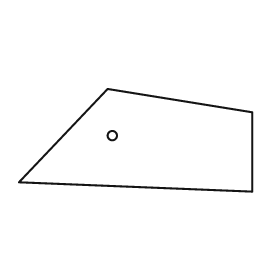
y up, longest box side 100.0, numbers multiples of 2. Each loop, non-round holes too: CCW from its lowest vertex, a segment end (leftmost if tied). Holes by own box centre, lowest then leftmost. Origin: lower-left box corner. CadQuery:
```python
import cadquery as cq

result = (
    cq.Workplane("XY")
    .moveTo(100.0, 0.0)
    .lineTo(100.0, 34.0)
    .lineTo(38.0, 44.0)
    .lineTo(0.0, 4.0)
    .close()
    .moveTo(40.0, 24.0)
    .circle(2.0)
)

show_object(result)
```